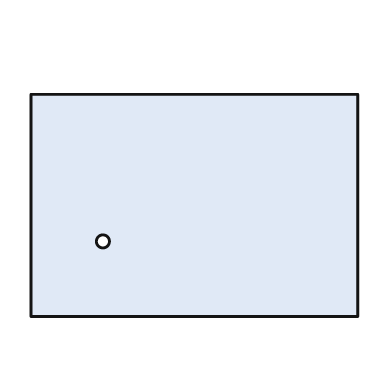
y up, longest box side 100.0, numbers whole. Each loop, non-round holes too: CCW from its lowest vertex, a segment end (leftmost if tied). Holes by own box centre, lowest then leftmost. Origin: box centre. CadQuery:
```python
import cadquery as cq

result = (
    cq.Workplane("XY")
    .moveTo(-50.0, -34.0)
    .lineTo(50.0, -34.0)
    .lineTo(50.0, 34.0)
    .lineTo(-50.0, 34.0)
    .close()
    .moveTo(-28.0, -11.0)
    .circle(2.0)
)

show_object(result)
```